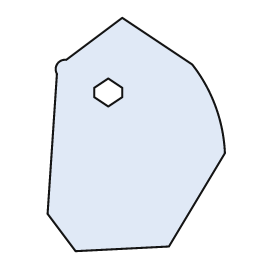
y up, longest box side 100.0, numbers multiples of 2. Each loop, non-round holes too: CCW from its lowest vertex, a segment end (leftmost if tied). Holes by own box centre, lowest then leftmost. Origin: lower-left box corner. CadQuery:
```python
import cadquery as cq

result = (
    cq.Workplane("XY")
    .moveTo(12.0, 0.0)
    .lineTo(52.0, 2.0)
    .lineTo(76.0, 42.0)
    .threePointArc((72.0, 62.0), (62.0, 80.0))
    .lineTo(32.0, 100.0)
    .lineTo(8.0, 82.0)
    .threePointArc((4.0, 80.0), (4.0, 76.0))
    .lineTo(0.0, 16.0)
    .close()
    .moveTo(26.0, 62.0)
    .lineTo(32.0, 66.0)
    .lineTo(32.0, 70.0)
    .lineTo(26.0, 74.0)
    .lineTo(20.0, 70.0)
    .lineTo(20.0, 66.0)
    .close()
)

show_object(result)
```